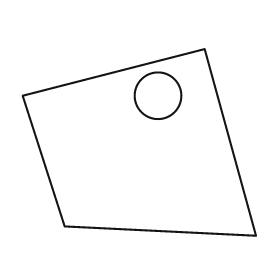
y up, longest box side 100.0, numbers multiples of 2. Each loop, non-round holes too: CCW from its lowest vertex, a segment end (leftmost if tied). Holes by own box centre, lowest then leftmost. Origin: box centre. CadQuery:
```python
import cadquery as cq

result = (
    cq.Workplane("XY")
    .moveTo(50.0, -40.0)
    .lineTo(28.0, 40.0)
    .lineTo(-50.0, 20.0)
    .lineTo(-32.0, -36.0)
    .close()
    .moveTo(8.0, 20.0)
    .circle(10.0)
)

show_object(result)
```